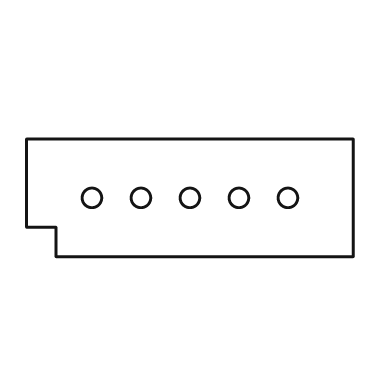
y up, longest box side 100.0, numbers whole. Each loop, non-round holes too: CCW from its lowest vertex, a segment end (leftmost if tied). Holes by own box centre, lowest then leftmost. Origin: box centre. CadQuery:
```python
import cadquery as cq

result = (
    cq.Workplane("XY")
    .moveTo(-41.0, -18.0)
    .lineTo(50.0, -18.0)
    .lineTo(50.0, 18.0)
    .lineTo(-50.0, 18.0)
    .lineTo(-50.0, -9.0)
    .lineTo(-41.0, -9.0)
    .close()
    .moveTo(-30.0, 0.0)
    .circle(3.0)
    .moveTo(-15.0, 0.0)
    .circle(3.0)
    .moveTo(0.0, 0.0)
    .circle(3.0)
    .moveTo(15.0, 0.0)
    .circle(3.0)
    .moveTo(30.0, 0.0)
    .circle(3.0)
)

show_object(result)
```